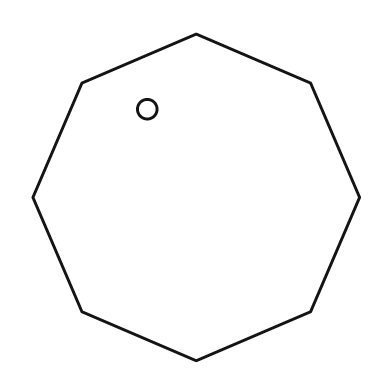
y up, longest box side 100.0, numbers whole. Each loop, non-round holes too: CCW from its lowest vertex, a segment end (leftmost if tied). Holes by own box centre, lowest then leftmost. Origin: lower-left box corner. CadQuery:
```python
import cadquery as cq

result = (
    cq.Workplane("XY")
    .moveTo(50.0, 0.0)
    .lineTo(85.0, 15.0)
    .lineTo(100.0, 50.0)
    .lineTo(85.0, 85.0)
    .lineTo(50.0, 100.0)
    .lineTo(15.0, 85.0)
    .lineTo(0.0, 50.0)
    .lineTo(15.0, 15.0)
    .close()
    .moveTo(35.0, 77.0)
    .circle(3.0)
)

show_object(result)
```